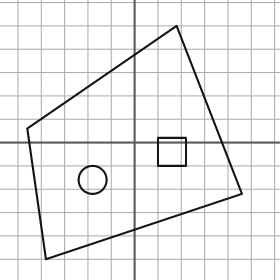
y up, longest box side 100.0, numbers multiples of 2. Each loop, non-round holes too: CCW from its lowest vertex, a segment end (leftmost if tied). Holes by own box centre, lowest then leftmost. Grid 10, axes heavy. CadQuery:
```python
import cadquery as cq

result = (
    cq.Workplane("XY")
    .moveTo(-38.0, -50.0)
    .lineTo(46.0, -22.0)
    .lineTo(18.0, 50.0)
    .lineTo(-46.0, 6.0)
    .close()
    .moveTo(-18.0, -16.0)
    .circle(6.0)
    .moveTo(10.0, -10.0)
    .lineTo(22.0, -10.0)
    .lineTo(22.0, 2.0)
    .lineTo(10.0, 2.0)
    .close()
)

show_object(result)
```